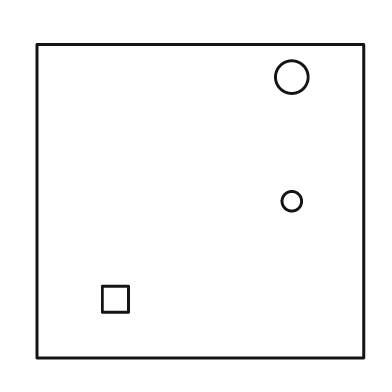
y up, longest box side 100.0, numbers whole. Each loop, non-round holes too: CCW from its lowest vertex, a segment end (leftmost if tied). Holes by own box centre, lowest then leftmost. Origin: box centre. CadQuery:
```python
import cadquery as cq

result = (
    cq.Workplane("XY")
    .moveTo(-50.0, -48.0)
    .lineTo(50.0, -48.0)
    .lineTo(50.0, 48.0)
    .lineTo(-50.0, 48.0)
    .close()
    .moveTo(-30.0, -34.0)
    .lineTo(-22.0, -34.0)
    .lineTo(-22.0, -26.0)
    .lineTo(-30.0, -26.0)
    .close()
    .moveTo(28.0, 0.0)
    .circle(3.0)
    .moveTo(28.0, 38.0)
    .circle(5.0)
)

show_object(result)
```